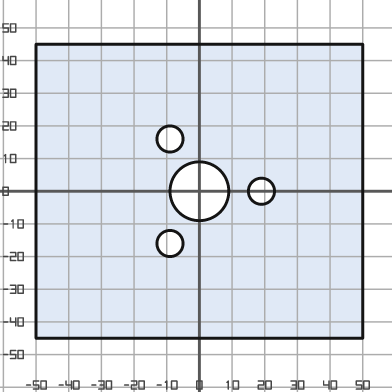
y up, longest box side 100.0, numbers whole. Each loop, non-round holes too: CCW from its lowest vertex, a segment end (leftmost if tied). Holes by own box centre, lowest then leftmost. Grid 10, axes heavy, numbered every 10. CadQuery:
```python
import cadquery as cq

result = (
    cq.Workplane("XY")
    .moveTo(-50.0, -45.0)
    .lineTo(50.0, -45.0)
    .lineTo(50.0, 45.0)
    .lineTo(-50.0, 45.0)
    .close()
    .moveTo(-9.0, -16.0)
    .circle(4.0)
    .moveTo(0.0, 0.0)
    .circle(9.0)
    .moveTo(19.0, 0.0)
    .circle(4.0)
    .moveTo(-9.0, 16.0)
    .circle(4.0)
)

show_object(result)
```